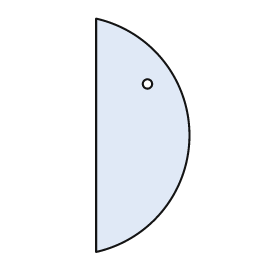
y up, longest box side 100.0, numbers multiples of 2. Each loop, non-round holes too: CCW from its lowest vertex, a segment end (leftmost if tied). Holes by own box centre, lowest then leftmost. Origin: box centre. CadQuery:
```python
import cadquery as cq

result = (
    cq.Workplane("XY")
    .moveTo(-20.0, -50.0)
    .threePointArc((20.0, 0.0), (-20.0, 50.0))
    .close()
    .moveTo(2.0, 22.0)
    .circle(2.0)
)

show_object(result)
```